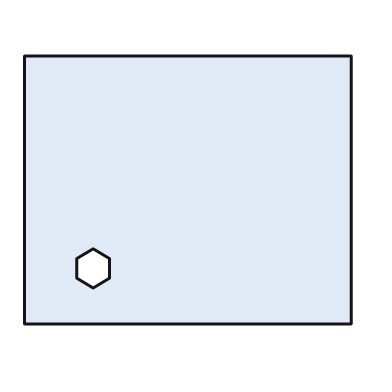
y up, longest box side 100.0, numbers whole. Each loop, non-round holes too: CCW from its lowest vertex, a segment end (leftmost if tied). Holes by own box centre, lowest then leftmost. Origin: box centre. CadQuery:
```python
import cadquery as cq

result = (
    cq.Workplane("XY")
    .moveTo(-50.0, -41.0)
    .lineTo(50.0, -41.0)
    .lineTo(50.0, 41.0)
    .lineTo(-50.0, 41.0)
    .close()
    .moveTo(-29.0, -30.0)
    .lineTo(-24.0, -27.0)
    .lineTo(-24.0, -21.0)
    .lineTo(-29.0, -18.0)
    .lineTo(-34.0, -21.0)
    .lineTo(-34.0, -27.0)
    .close()
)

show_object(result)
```